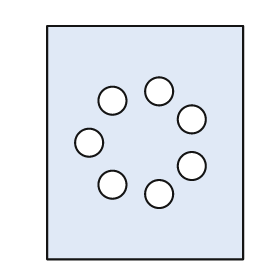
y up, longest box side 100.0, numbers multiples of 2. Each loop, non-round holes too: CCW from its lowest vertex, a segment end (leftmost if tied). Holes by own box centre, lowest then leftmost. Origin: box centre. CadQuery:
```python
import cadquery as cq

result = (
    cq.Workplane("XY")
    .moveTo(-42.0, -50.0)
    .lineTo(42.0, -50.0)
    .lineTo(42.0, 50.0)
    .lineTo(-42.0, 50.0)
    .close()
    .moveTo(6.0, -22.0)
    .circle(6.0)
    .moveTo(-14.0, -18.0)
    .circle(6.0)
    .moveTo(20.0, -10.0)
    .circle(6.0)
    .moveTo(-24.0, 0.0)
    .circle(6.0)
    .moveTo(20.0, 10.0)
    .circle(6.0)
    .moveTo(-14.0, 18.0)
    .circle(6.0)
    .moveTo(6.0, 22.0)
    .circle(6.0)
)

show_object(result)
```